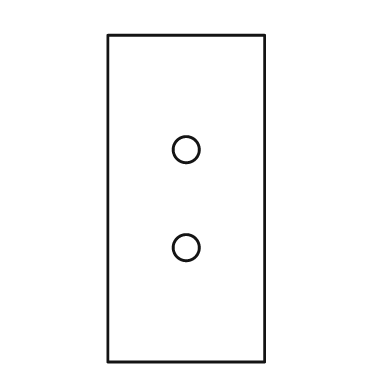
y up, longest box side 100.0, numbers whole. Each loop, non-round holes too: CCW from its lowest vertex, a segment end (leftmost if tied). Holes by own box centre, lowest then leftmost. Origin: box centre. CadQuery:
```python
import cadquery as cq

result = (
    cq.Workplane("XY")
    .moveTo(-24.0, -50.0)
    .lineTo(24.0, -50.0)
    .lineTo(24.0, 50.0)
    .lineTo(-24.0, 50.0)
    .close()
    .moveTo(0.0, -15.0)
    .circle(4.0)
    .moveTo(0.0, 15.0)
    .circle(4.0)
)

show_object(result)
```